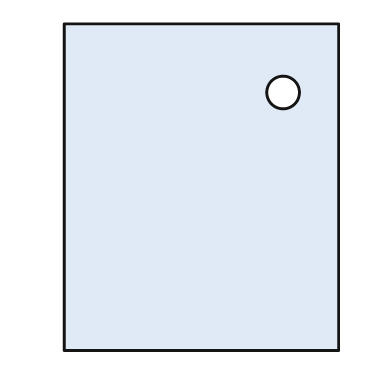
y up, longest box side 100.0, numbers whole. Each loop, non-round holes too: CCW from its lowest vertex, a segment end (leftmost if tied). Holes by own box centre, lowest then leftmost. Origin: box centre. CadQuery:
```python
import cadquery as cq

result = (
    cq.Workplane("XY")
    .moveTo(-42.0, -50.0)
    .lineTo(42.0, -50.0)
    .lineTo(42.0, 50.0)
    .lineTo(-42.0, 50.0)
    .close()
    .moveTo(25.0, 29.0)
    .circle(5.0)
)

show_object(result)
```